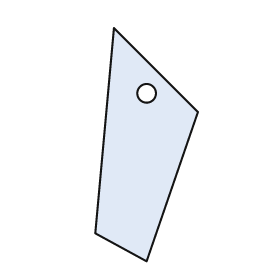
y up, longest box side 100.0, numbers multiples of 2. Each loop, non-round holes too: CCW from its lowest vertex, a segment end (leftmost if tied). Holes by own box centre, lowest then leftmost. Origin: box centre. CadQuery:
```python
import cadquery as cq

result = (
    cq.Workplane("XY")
    .moveTo(0.0, -50.0)
    .lineTo(22.0, 14.0)
    .lineTo(-14.0, 50.0)
    .lineTo(-22.0, -38.0)
    .close()
    .moveTo(0.0, 22.0)
    .circle(4.0)
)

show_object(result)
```